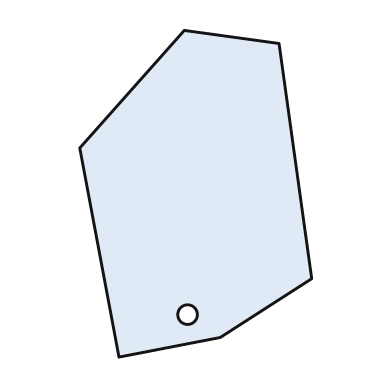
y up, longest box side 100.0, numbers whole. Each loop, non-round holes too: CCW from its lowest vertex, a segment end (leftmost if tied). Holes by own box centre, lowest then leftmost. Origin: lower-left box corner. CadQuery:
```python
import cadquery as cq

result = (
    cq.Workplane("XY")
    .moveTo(12.0, 0.0)
    .lineTo(43.0, 6.0)
    .lineTo(71.0, 24.0)
    .lineTo(61.0, 96.0)
    .lineTo(32.0, 100.0)
    .lineTo(0.0, 64.0)
    .close()
    .moveTo(33.0, 13.0)
    .circle(3.0)
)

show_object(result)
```